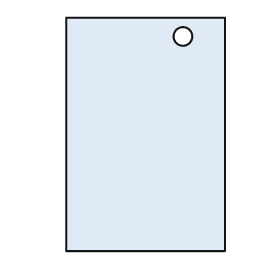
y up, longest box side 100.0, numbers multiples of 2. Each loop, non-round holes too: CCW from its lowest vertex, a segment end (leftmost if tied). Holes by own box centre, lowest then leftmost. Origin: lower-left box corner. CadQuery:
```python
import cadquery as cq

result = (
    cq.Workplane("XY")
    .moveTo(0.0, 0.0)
    .lineTo(68.0, 0.0)
    .lineTo(68.0, 100.0)
    .lineTo(0.0, 100.0)
    .close()
    .moveTo(50.0, 92.0)
    .circle(4.0)
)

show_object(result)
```